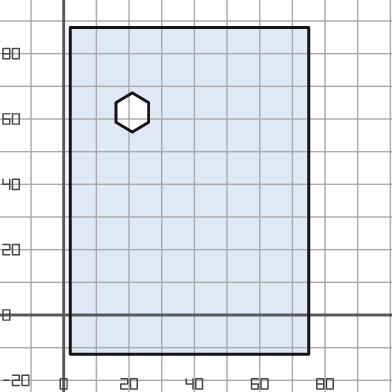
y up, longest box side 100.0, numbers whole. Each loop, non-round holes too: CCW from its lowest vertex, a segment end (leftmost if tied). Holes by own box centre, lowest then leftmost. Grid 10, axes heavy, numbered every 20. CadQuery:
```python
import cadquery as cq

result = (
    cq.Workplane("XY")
    .moveTo(2.0, -12.0)
    .lineTo(75.0, -12.0)
    .lineTo(75.0, 88.0)
    .lineTo(2.0, 88.0)
    .close()
    .moveTo(21.0, 56.0)
    .lineTo(26.0, 59.0)
    .lineTo(26.0, 65.0)
    .lineTo(21.0, 68.0)
    .lineTo(16.0, 65.0)
    .lineTo(16.0, 59.0)
    .close()
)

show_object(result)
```